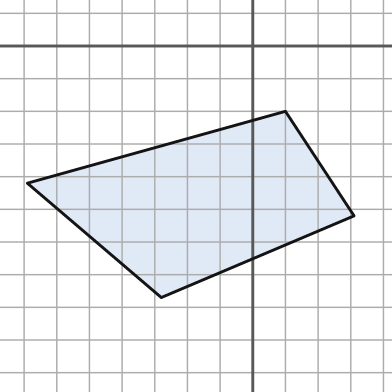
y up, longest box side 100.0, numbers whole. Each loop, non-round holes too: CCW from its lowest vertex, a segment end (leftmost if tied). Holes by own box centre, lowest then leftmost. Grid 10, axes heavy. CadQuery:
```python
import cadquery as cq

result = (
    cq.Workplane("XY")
    .moveTo(-28.0, -77.0)
    .lineTo(31.0, -52.0)
    .lineTo(10.0, -20.0)
    .lineTo(-69.0, -42.0)
    .close()
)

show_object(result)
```